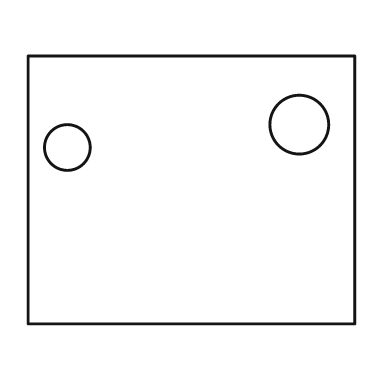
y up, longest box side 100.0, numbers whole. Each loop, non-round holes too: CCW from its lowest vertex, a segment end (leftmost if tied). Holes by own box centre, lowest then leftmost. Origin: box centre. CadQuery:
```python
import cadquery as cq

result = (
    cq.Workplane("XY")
    .moveTo(-50.0, -41.0)
    .lineTo(50.0, -41.0)
    .lineTo(50.0, 41.0)
    .lineTo(-50.0, 41.0)
    .close()
    .moveTo(-38.0, 13.0)
    .circle(7.0)
    .moveTo(33.0, 20.0)
    .circle(9.0)
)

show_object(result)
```